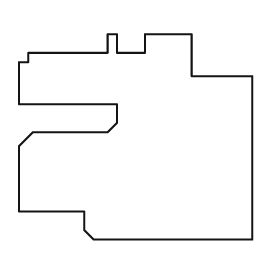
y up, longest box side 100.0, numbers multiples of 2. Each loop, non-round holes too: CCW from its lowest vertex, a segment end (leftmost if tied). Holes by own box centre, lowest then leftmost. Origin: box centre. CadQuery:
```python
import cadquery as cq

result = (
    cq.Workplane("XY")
    .moveTo(-18.0, -44.0)
    .lineTo(50.0, -44.0)
    .lineTo(50.0, 26.0)
    .lineTo(24.0, 26.0)
    .lineTo(24.0, 44.0)
    .lineTo(4.0, 44.0)
    .lineTo(4.0, 36.0)
    .lineTo(-8.0, 36.0)
    .lineTo(-8.0, 44.0)
    .lineTo(-12.0, 44.0)
    .lineTo(-12.0, 36.0)
    .lineTo(-46.0, 36.0)
    .lineTo(-46.0, 32.0)
    .lineTo(-50.0, 32.0)
    .lineTo(-50.0, 14.0)
    .lineTo(-8.0, 14.0)
    .lineTo(-8.0, 6.0)
    .lineTo(-12.0, 2.0)
    .lineTo(-44.0, 2.0)
    .lineTo(-50.0, -4.0)
    .lineTo(-50.0, -32.0)
    .lineTo(-22.0, -32.0)
    .lineTo(-22.0, -40.0)
    .close()
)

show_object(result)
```